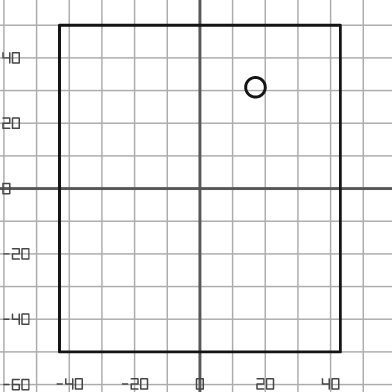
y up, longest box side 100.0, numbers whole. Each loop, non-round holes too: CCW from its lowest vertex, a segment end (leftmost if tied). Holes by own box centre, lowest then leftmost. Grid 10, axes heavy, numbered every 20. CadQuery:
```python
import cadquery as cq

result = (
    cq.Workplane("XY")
    .moveTo(-43.0, -50.0)
    .lineTo(43.0, -50.0)
    .lineTo(43.0, 50.0)
    .lineTo(-43.0, 50.0)
    .close()
    .moveTo(17.0, 31.0)
    .circle(3.0)
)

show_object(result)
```